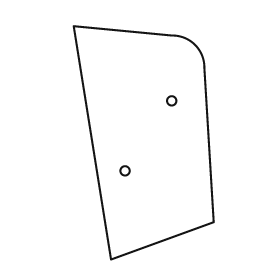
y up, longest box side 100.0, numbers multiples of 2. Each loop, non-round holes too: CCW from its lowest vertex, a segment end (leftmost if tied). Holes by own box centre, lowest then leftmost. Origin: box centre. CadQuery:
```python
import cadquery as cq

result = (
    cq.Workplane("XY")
    .moveTo(-14.0, -50.0)
    .lineTo(30.0, -34.0)
    .lineTo(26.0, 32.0)
    .threePointArc((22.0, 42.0), (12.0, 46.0))
    .lineTo(-30.0, 50.0)
    .close()
    .moveTo(-8.0, -12.0)
    .circle(2.0)
    .moveTo(12.0, 18.0)
    .circle(2.0)
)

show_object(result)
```